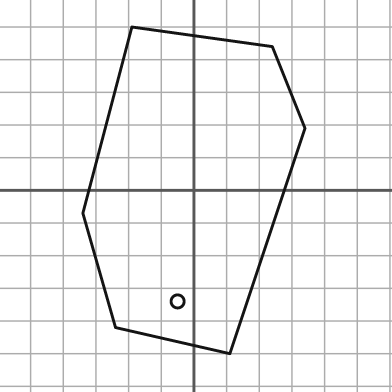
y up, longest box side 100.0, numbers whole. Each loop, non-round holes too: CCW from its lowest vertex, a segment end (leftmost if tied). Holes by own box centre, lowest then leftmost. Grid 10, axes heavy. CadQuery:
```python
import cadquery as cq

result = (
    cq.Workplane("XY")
    .moveTo(11.0, -50.0)
    .lineTo(34.0, 19.0)
    .lineTo(24.0, 44.0)
    .lineTo(-19.0, 50.0)
    .lineTo(-34.0, -7.0)
    .lineTo(-24.0, -42.0)
    .close()
    .moveTo(-5.0, -34.0)
    .circle(2.0)
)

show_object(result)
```